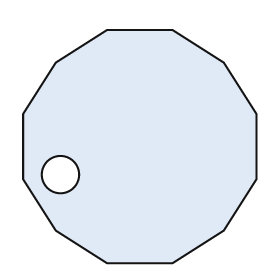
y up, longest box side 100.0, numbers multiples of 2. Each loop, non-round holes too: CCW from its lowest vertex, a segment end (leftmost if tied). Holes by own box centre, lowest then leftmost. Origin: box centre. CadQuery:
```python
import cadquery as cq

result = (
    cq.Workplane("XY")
    .moveTo(-14.0, -50.0)
    .lineTo(14.0, -50.0)
    .lineTo(36.0, -36.0)
    .lineTo(50.0, -14.0)
    .lineTo(50.0, 14.0)
    .lineTo(36.0, 36.0)
    .lineTo(14.0, 50.0)
    .lineTo(-14.0, 50.0)
    .lineTo(-36.0, 36.0)
    .lineTo(-50.0, 14.0)
    .lineTo(-50.0, -14.0)
    .lineTo(-36.0, -36.0)
    .close()
    .moveTo(-34.0, -12.0)
    .circle(8.0)
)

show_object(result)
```